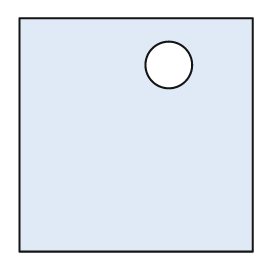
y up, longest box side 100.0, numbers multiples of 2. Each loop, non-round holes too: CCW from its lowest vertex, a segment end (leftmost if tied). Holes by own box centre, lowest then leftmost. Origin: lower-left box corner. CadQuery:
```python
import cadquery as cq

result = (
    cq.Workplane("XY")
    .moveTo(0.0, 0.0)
    .lineTo(100.0, 0.0)
    .lineTo(100.0, 100.0)
    .lineTo(0.0, 100.0)
    .close()
    .moveTo(64.0, 80.0)
    .circle(10.0)
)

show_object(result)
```